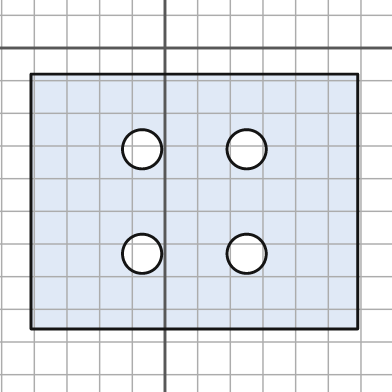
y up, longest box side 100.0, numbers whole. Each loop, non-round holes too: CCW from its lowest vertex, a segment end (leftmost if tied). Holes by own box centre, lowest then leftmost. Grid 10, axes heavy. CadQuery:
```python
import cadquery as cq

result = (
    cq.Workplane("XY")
    .moveTo(-41.0, -86.0)
    .lineTo(59.0, -86.0)
    .lineTo(59.0, -8.0)
    .lineTo(-41.0, -8.0)
    .close()
    .moveTo(-7.0, -63.0)
    .circle(6.0)
    .moveTo(25.0, -63.0)
    .circle(6.0)
    .moveTo(-7.0, -31.0)
    .circle(6.0)
    .moveTo(25.0, -31.0)
    .circle(6.0)
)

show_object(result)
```